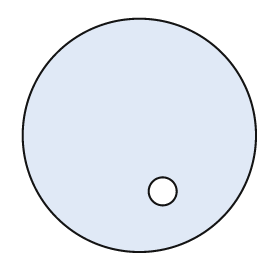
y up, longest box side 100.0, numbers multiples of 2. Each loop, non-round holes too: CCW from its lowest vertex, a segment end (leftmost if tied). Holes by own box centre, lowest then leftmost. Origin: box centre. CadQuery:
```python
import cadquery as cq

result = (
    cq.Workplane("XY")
    .moveTo(0.0, 0.0)
    .circle(50.0)
    .moveTo(10.0, -24.0)
    .circle(6.0)
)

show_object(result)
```